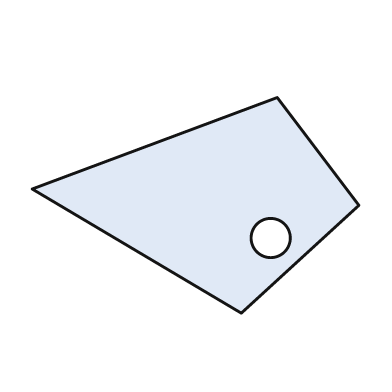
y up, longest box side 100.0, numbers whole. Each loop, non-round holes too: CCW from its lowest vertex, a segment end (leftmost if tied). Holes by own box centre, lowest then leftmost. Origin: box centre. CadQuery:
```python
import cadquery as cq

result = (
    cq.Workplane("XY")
    .moveTo(14.0, -33.0)
    .lineTo(50.0, 0.0)
    .lineTo(25.0, 33.0)
    .lineTo(-50.0, 5.0)
    .close()
    .moveTo(23.0, -10.0)
    .circle(6.0)
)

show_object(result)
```